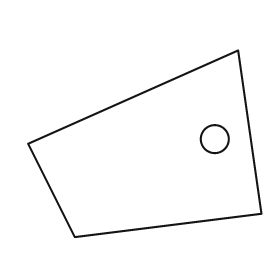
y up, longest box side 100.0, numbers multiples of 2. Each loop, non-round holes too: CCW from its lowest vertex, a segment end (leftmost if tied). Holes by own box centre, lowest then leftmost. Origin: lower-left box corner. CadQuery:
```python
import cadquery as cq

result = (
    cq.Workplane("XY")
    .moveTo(20.0, 0.0)
    .lineTo(100.0, 10.0)
    .lineTo(90.0, 80.0)
    .lineTo(0.0, 40.0)
    .close()
    .moveTo(80.0, 42.0)
    .circle(6.0)
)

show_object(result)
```